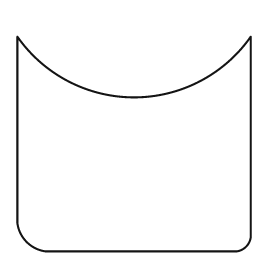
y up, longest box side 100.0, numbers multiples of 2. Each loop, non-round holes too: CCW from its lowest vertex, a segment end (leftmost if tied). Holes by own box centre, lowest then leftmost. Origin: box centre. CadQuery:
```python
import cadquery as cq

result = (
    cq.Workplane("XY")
    .moveTo(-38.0, -46.0)
    .lineTo(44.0, -46.0)
    .threePointArc((48.0, -44.0), (50.0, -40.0))
    .lineTo(50.0, 46.0)
    .threePointArc((0.0, 20.0), (-50.0, 46.0))
    .lineTo(-50.0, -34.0)
    .threePointArc((-46.0, -42.0), (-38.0, -46.0))
    .close()
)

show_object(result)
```